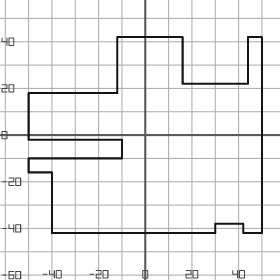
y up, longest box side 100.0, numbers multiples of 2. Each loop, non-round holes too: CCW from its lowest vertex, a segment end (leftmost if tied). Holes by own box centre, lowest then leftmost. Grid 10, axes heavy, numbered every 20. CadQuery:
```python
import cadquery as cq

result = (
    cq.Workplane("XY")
    .moveTo(-40.0, -42.0)
    .lineTo(30.0, -42.0)
    .lineTo(30.0, -38.0)
    .lineTo(42.0, -38.0)
    .lineTo(42.0, -42.0)
    .lineTo(50.0, -42.0)
    .lineTo(50.0, 42.0)
    .lineTo(44.0, 42.0)
    .lineTo(44.0, 22.0)
    .lineTo(16.0, 22.0)
    .lineTo(16.0, 42.0)
    .lineTo(-12.0, 42.0)
    .lineTo(-12.0, 18.0)
    .lineTo(-50.0, 18.0)
    .lineTo(-50.0, -2.0)
    .lineTo(-10.0, -2.0)
    .lineTo(-10.0, -10.0)
    .lineTo(-50.0, -10.0)
    .lineTo(-50.0, -16.0)
    .lineTo(-40.0, -16.0)
    .close()
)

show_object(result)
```